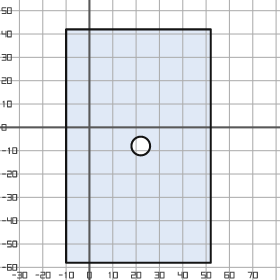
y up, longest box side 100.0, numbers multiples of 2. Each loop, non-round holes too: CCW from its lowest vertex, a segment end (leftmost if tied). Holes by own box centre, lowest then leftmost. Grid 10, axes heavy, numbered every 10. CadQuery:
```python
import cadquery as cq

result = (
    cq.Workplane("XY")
    .moveTo(-10.0, -58.0)
    .lineTo(52.0, -58.0)
    .lineTo(52.0, 42.0)
    .lineTo(-10.0, 42.0)
    .close()
    .moveTo(22.0, -8.0)
    .circle(4.0)
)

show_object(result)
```